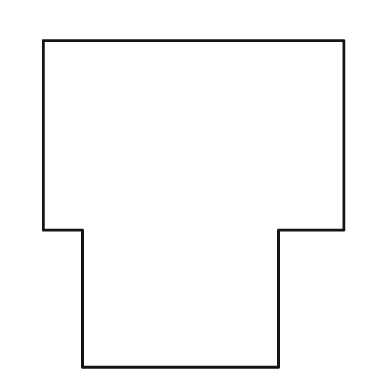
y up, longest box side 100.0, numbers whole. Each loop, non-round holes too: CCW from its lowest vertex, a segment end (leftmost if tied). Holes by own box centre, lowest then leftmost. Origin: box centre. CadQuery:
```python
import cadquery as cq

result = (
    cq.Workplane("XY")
    .moveTo(-34.0, -50.0)
    .lineTo(26.0, -50.0)
    .lineTo(26.0, -8.0)
    .lineTo(46.0, -8.0)
    .lineTo(46.0, 50.0)
    .lineTo(-46.0, 50.0)
    .lineTo(-46.0, -8.0)
    .lineTo(-34.0, -8.0)
    .close()
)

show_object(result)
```